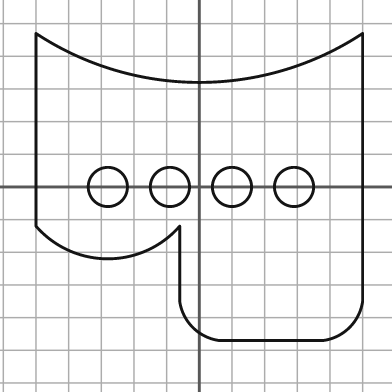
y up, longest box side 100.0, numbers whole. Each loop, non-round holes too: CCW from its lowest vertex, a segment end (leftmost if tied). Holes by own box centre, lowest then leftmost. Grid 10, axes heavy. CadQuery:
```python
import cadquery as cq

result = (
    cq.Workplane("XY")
    .moveTo(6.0, -47.0)
    .lineTo(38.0, -47.0)
    .threePointArc((46.0, -43.0), (50.0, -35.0))
    .lineTo(50.0, 47.0)
    .threePointArc((0.0, 32.0), (-50.0, 47.0))
    .lineTo(-50.0, -12.0)
    .threePointArc((-28.0, -22.0), (-6.0, -12.0))
    .lineTo(-6.0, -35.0)
    .threePointArc((-2.0, -43.0), (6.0, -47.0))
    .close()
    .moveTo(-28.0, 0.0)
    .circle(6.0)
    .moveTo(-9.0, 0.0)
    .circle(6.0)
    .moveTo(10.0, 0.0)
    .circle(6.0)
    .moveTo(29.0, 0.0)
    .circle(6.0)
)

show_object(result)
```